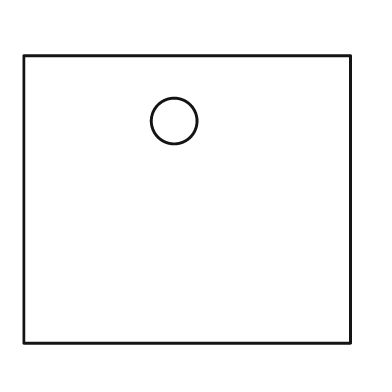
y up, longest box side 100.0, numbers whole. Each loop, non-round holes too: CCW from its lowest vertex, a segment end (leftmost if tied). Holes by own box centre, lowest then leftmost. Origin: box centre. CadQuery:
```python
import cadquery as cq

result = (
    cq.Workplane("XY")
    .moveTo(-50.0, -44.0)
    .lineTo(50.0, -44.0)
    .lineTo(50.0, 44.0)
    .lineTo(-50.0, 44.0)
    .close()
    .moveTo(-4.0, 24.0)
    .circle(7.0)
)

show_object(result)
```